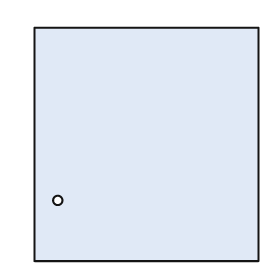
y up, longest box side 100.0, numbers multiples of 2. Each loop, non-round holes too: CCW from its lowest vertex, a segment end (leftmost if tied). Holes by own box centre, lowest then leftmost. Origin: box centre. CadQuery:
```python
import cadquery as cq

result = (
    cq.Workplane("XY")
    .moveTo(-48.0, -50.0)
    .lineTo(48.0, -50.0)
    .lineTo(48.0, 50.0)
    .lineTo(-48.0, 50.0)
    .close()
    .moveTo(-38.0, -24.0)
    .circle(2.0)
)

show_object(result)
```